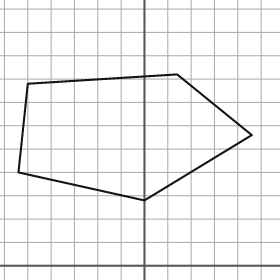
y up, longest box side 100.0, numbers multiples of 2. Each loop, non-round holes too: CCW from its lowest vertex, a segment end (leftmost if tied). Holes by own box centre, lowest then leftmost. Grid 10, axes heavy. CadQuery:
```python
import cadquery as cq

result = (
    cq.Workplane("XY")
    .moveTo(0.0, 28.0)
    .lineTo(46.0, 56.0)
    .lineTo(14.0, 82.0)
    .lineTo(-50.0, 78.0)
    .lineTo(-54.0, 40.0)
    .close()
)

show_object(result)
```